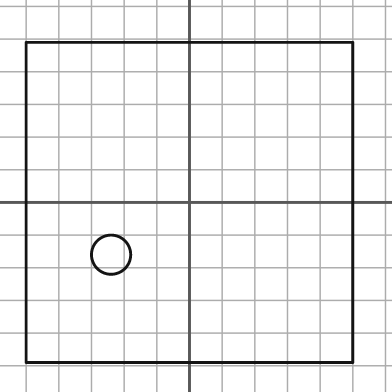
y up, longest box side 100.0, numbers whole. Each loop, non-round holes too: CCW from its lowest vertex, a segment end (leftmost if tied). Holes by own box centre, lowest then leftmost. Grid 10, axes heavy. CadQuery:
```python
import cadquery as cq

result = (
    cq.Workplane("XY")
    .moveTo(-50.0, -49.0)
    .lineTo(50.0, -49.0)
    .lineTo(50.0, 49.0)
    .lineTo(-50.0, 49.0)
    .close()
    .moveTo(-24.0, -16.0)
    .circle(6.0)
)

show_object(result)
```